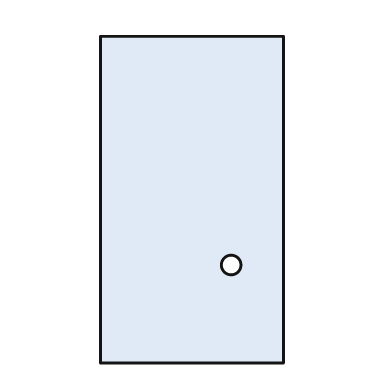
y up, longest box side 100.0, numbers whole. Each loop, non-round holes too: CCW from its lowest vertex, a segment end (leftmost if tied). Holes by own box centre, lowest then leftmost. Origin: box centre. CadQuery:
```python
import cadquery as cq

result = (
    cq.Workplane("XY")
    .moveTo(-28.0, -50.0)
    .lineTo(28.0, -50.0)
    .lineTo(28.0, 50.0)
    .lineTo(-28.0, 50.0)
    .close()
    .moveTo(12.0, -20.0)
    .circle(3.0)
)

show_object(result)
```